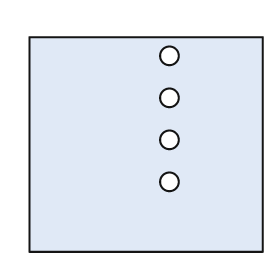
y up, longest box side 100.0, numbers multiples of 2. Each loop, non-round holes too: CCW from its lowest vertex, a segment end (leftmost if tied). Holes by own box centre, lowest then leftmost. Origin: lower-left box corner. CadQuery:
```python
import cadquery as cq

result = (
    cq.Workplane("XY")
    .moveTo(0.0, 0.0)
    .lineTo(100.0, 0.0)
    .lineTo(100.0, 92.0)
    .lineTo(0.0, 92.0)
    .close()
    .moveTo(60.0, 30.0)
    .circle(4.0)
    .moveTo(60.0, 48.0)
    .circle(4.0)
    .moveTo(60.0, 66.0)
    .circle(4.0)
    .moveTo(60.0, 84.0)
    .circle(4.0)
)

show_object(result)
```